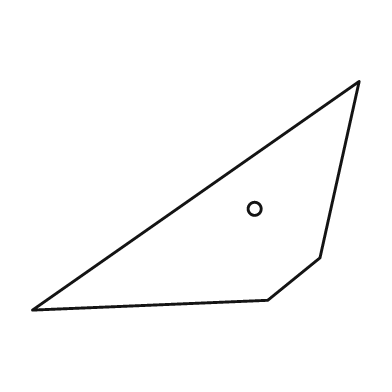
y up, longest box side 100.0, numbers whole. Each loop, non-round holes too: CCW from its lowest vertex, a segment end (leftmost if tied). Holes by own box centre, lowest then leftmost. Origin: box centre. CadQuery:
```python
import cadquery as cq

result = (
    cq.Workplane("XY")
    .moveTo(-50.0, -35.0)
    .lineTo(22.0, -32.0)
    .lineTo(38.0, -19.0)
    .lineTo(50.0, 35.0)
    .close()
    .moveTo(18.0, -4.0)
    .circle(2.0)
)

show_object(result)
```